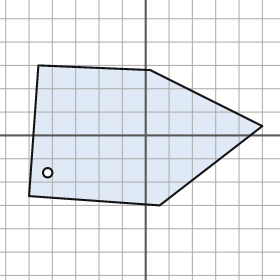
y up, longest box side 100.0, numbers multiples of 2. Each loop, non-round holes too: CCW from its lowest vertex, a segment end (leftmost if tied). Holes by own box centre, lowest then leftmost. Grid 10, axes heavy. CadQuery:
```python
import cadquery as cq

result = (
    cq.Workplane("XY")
    .moveTo(6.0, -30.0)
    .lineTo(50.0, 4.0)
    .lineTo(2.0, 28.0)
    .lineTo(-46.0, 30.0)
    .lineTo(-50.0, -26.0)
    .close()
    .moveTo(-42.0, -16.0)
    .circle(2.0)
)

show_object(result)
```